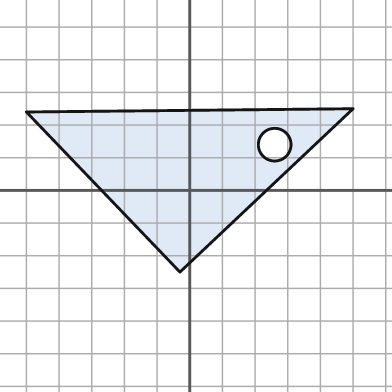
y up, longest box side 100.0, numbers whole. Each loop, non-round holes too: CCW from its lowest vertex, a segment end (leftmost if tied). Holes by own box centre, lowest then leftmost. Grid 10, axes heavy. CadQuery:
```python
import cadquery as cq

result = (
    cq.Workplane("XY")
    .moveTo(-3.0, -25.0)
    .lineTo(50.0, 25.0)
    .lineTo(-50.0, 24.0)
    .close()
    .moveTo(26.0, 14.0)
    .circle(5.0)
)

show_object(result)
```